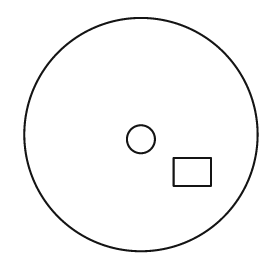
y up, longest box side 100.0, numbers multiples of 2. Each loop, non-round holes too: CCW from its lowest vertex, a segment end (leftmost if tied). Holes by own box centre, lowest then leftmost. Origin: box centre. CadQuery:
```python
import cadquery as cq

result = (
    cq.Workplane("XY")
    .moveTo(0.0, 0.0)
    .circle(50.0)
    .moveTo(14.0, -22.0)
    .lineTo(30.0, -22.0)
    .lineTo(30.0, -10.0)
    .lineTo(14.0, -10.0)
    .close()
    .moveTo(0.0, -2.0)
    .circle(6.0)
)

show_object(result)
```